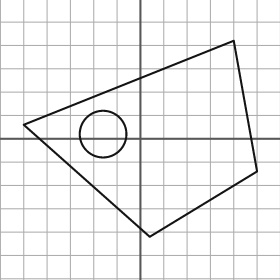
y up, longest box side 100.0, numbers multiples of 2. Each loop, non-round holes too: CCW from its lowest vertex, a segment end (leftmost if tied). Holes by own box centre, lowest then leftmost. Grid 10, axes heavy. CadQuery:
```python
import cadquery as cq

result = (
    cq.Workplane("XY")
    .moveTo(4.0, -42.0)
    .lineTo(50.0, -14.0)
    .lineTo(40.0, 42.0)
    .lineTo(-50.0, 6.0)
    .close()
    .moveTo(-16.0, 2.0)
    .circle(10.0)
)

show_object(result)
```